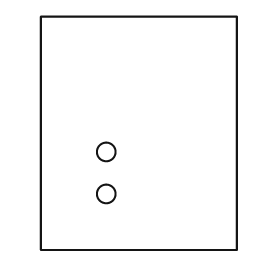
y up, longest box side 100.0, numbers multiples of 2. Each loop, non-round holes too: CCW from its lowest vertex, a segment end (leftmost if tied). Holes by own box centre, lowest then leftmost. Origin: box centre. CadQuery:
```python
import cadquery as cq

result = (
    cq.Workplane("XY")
    .moveTo(-42.0, -50.0)
    .lineTo(42.0, -50.0)
    .lineTo(42.0, 50.0)
    .lineTo(-42.0, 50.0)
    .close()
    .moveTo(-14.0, -26.0)
    .circle(4.0)
    .moveTo(-14.0, -8.0)
    .circle(4.0)
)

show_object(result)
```